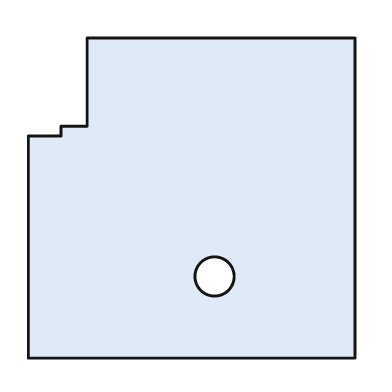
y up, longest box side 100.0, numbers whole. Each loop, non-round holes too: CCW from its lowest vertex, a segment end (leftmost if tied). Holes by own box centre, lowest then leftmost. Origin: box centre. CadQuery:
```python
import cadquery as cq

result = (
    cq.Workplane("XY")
    .moveTo(-50.0, -49.0)
    .lineTo(50.0, -49.0)
    .lineTo(50.0, 49.0)
    .lineTo(-32.0, 49.0)
    .lineTo(-32.0, 22.0)
    .lineTo(-40.0, 22.0)
    .lineTo(-40.0, 19.0)
    .lineTo(-50.0, 19.0)
    .close()
    .moveTo(7.0, -24.0)
    .circle(6.0)
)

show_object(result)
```